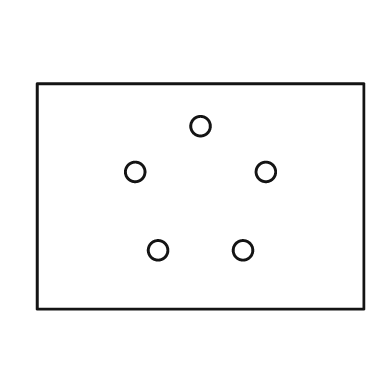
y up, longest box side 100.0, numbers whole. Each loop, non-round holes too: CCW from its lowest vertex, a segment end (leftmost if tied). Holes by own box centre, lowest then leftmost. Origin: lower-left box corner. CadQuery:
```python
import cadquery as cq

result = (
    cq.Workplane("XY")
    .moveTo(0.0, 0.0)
    .lineTo(100.0, 0.0)
    .lineTo(100.0, 69.0)
    .lineTo(0.0, 69.0)
    .close()
    .moveTo(37.0, 18.0)
    .circle(3.0)
    .moveTo(63.0, 18.0)
    .circle(3.0)
    .moveTo(30.0, 42.0)
    .circle(3.0)
    .moveTo(70.0, 42.0)
    .circle(3.0)
    .moveTo(50.0, 56.0)
    .circle(3.0)
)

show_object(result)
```